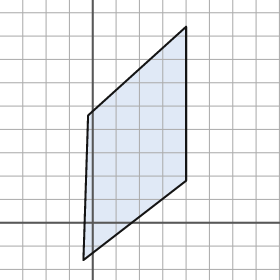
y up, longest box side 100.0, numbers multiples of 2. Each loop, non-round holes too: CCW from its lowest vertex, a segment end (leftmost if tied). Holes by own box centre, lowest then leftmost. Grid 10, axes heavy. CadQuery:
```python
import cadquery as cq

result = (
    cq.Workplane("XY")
    .moveTo(-4.0, -16.0)
    .lineTo(40.0, 18.0)
    .lineTo(40.0, 84.0)
    .lineTo(-2.0, 46.0)
    .close()
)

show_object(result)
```